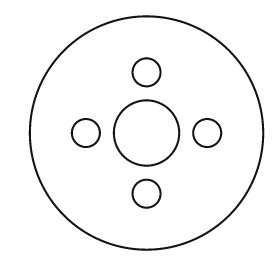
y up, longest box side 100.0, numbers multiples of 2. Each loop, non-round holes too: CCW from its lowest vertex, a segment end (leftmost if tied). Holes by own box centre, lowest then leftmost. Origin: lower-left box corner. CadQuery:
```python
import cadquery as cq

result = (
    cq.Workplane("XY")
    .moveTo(50.0, 50.0)
    .circle(50.0)
    .moveTo(50.0, 24.0)
    .circle(6.0)
    .moveTo(24.0, 50.0)
    .circle(6.0)
    .moveTo(50.0, 50.0)
    .circle(14.0)
    .moveTo(76.0, 50.0)
    .circle(6.0)
    .moveTo(50.0, 76.0)
    .circle(6.0)
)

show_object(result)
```